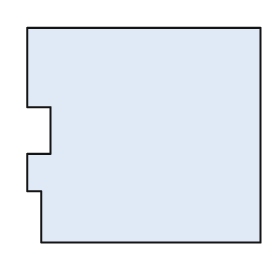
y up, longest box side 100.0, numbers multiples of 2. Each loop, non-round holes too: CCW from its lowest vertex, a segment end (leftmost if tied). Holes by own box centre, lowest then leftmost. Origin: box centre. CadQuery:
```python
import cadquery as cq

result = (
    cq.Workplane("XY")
    .moveTo(-44.0, -46.0)
    .lineTo(50.0, -46.0)
    .lineTo(50.0, 46.0)
    .lineTo(-50.0, 46.0)
    .lineTo(-50.0, 12.0)
    .lineTo(-40.0, 12.0)
    .lineTo(-40.0, -8.0)
    .lineTo(-50.0, -8.0)
    .lineTo(-50.0, -24.0)
    .lineTo(-44.0, -24.0)
    .close()
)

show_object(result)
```